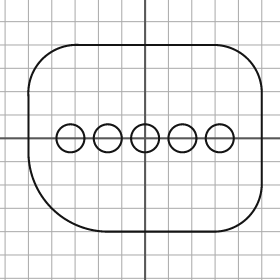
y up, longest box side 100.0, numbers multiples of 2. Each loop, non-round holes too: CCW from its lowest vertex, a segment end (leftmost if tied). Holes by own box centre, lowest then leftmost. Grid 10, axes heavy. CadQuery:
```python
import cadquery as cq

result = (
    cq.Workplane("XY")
    .moveTo(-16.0, -40.0)
    .lineTo(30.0, -40.0)
    .threePointArc((44.0, -34.0), (50.0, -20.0))
    .lineTo(50.0, 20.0)
    .threePointArc((44.0, 34.0), (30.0, 40.0))
    .lineTo(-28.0, 40.0)
    .threePointArc((-44.0, 34.0), (-50.0, 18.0))
    .lineTo(-50.0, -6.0)
    .threePointArc((-40.0, -30.0), (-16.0, -40.0))
    .close()
    .moveTo(-32.0, 0.0)
    .circle(6.0)
    .moveTo(-16.0, 0.0)
    .circle(6.0)
    .moveTo(0.0, 0.0)
    .circle(6.0)
    .moveTo(16.0, 0.0)
    .circle(6.0)
    .moveTo(32.0, 0.0)
    .circle(6.0)
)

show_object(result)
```